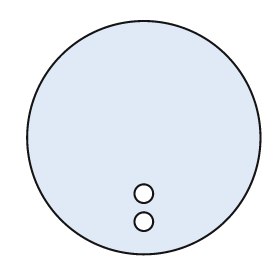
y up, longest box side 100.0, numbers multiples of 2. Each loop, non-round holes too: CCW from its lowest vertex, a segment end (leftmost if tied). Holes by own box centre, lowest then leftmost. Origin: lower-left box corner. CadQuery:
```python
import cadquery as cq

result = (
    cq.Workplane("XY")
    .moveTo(50.0, 50.0)
    .circle(50.0)
    .moveTo(50.0, 14.0)
    .circle(4.0)
    .moveTo(50.0, 26.0)
    .circle(4.0)
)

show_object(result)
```